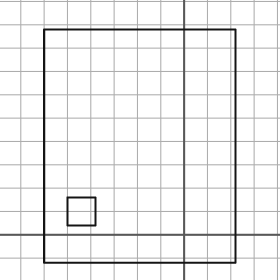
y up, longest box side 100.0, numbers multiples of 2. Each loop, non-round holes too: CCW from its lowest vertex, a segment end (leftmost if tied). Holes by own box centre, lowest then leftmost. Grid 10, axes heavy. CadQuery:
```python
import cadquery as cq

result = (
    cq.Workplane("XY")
    .moveTo(-60.0, -12.0)
    .lineTo(22.0, -12.0)
    .lineTo(22.0, 88.0)
    .lineTo(-60.0, 88.0)
    .close()
    .moveTo(-50.0, 4.0)
    .lineTo(-38.0, 4.0)
    .lineTo(-38.0, 16.0)
    .lineTo(-50.0, 16.0)
    .close()
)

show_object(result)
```